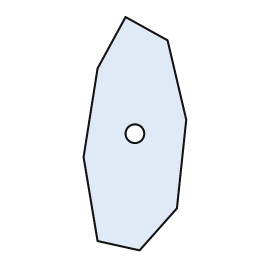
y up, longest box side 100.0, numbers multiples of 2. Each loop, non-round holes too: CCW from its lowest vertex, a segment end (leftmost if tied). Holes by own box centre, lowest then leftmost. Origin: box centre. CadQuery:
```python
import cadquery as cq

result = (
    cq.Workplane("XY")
    .moveTo(2.0, -50.0)
    .lineTo(18.0, -32.0)
    .lineTo(22.0, 6.0)
    .lineTo(14.0, 40.0)
    .lineTo(-4.0, 50.0)
    .lineTo(-16.0, 28.0)
    .lineTo(-22.0, -10.0)
    .lineTo(-16.0, -46.0)
    .close()
    .moveTo(0.0, 0.0)
    .circle(4.0)
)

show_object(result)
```